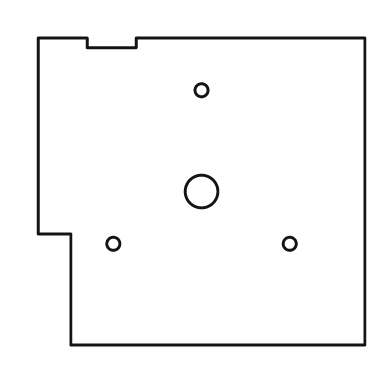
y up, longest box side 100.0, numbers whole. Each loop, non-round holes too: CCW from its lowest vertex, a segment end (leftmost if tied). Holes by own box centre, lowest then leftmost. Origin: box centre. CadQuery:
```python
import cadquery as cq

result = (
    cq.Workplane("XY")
    .moveTo(-40.0, -47.0)
    .lineTo(50.0, -47.0)
    .lineTo(50.0, 47.0)
    .lineTo(-20.0, 47.0)
    .lineTo(-20.0, 44.0)
    .lineTo(-35.0, 44.0)
    .lineTo(-35.0, 47.0)
    .lineTo(-50.0, 47.0)
    .lineTo(-50.0, -13.0)
    .lineTo(-40.0, -13.0)
    .close()
    .moveTo(-27.0, -16.0)
    .circle(2.0)
    .moveTo(27.0, -16.0)
    .circle(2.0)
    .moveTo(0.0, 0.0)
    .circle(5.0)
    .moveTo(0.0, 31.0)
    .circle(2.0)
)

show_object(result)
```